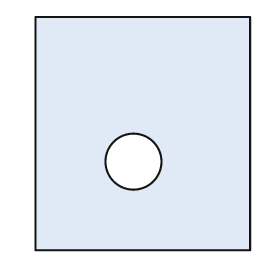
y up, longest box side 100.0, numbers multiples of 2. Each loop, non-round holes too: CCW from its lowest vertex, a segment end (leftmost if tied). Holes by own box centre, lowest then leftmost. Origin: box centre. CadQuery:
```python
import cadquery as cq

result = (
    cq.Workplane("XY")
    .moveTo(-46.0, -50.0)
    .lineTo(46.0, -50.0)
    .lineTo(46.0, 50.0)
    .lineTo(-46.0, 50.0)
    .close()
    .moveTo(-4.0, -12.0)
    .circle(12.0)
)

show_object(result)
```